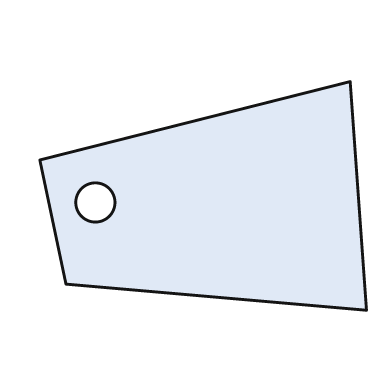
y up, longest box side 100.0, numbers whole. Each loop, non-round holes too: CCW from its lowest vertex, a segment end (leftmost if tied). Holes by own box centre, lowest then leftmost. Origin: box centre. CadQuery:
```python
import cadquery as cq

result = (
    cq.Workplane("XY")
    .moveTo(50.0, -35.0)
    .lineTo(45.0, 35.0)
    .lineTo(-50.0, 11.0)
    .lineTo(-42.0, -27.0)
    .close()
    .moveTo(-33.0, -2.0)
    .circle(6.0)
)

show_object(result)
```